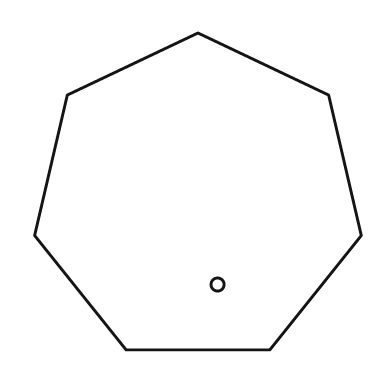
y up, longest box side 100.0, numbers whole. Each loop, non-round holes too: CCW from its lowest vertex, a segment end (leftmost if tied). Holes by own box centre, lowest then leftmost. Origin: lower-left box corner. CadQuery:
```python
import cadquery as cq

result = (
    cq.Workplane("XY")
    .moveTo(28.0, 0.0)
    .lineTo(72.0, 0.0)
    .lineTo(100.0, 35.0)
    .lineTo(90.0, 78.0)
    .lineTo(50.0, 97.0)
    .lineTo(10.0, 78.0)
    .lineTo(0.0, 35.0)
    .close()
    .moveTo(56.0, 20.0)
    .circle(2.0)
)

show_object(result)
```